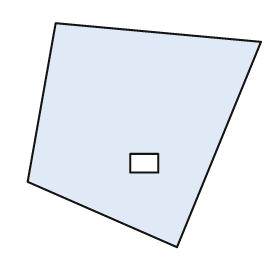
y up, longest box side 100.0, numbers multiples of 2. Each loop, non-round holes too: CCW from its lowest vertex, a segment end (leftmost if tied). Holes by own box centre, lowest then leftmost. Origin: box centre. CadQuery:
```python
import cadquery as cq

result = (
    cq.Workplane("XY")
    .moveTo(14.0, -48.0)
    .lineTo(50.0, 40.0)
    .lineTo(-38.0, 48.0)
    .lineTo(-50.0, -20.0)
    .close()
    .moveTo(-6.0, -16.0)
    .lineTo(6.0, -16.0)
    .lineTo(6.0, -8.0)
    .lineTo(-6.0, -8.0)
    .close()
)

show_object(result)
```